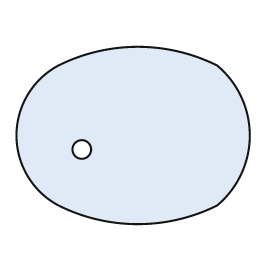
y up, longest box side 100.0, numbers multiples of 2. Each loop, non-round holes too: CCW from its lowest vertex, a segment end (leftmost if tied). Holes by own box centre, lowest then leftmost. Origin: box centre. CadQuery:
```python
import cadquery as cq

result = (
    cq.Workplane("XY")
    .moveTo(-32.0, -30.0)
    .threePointArc((2.0, -38.0), (36.0, -30.0))
    .threePointArc((50.0, 0.0), (36.0, 30.0))
    .threePointArc((2.0, 38.0), (-32.0, 30.0))
    .threePointArc((-50.0, 0.0), (-32.0, -30.0))
    .close()
    .moveTo(-22.0, -6.0)
    .circle(4.0)
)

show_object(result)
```